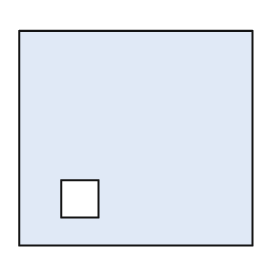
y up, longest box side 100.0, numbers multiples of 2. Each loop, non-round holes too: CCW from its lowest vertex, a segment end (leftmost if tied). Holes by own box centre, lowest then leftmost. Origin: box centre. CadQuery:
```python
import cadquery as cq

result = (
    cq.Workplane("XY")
    .moveTo(-50.0, -46.0)
    .lineTo(50.0, -46.0)
    .lineTo(50.0, 46.0)
    .lineTo(-50.0, 46.0)
    .close()
    .moveTo(-32.0, -34.0)
    .lineTo(-16.0, -34.0)
    .lineTo(-16.0, -18.0)
    .lineTo(-32.0, -18.0)
    .close()
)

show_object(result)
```